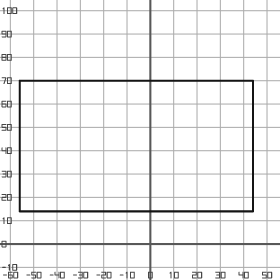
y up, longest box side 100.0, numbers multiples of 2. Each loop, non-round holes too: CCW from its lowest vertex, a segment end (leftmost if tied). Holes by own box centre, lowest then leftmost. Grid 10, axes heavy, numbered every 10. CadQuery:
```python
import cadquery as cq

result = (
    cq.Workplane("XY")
    .moveTo(-56.0, 14.0)
    .lineTo(44.0, 14.0)
    .lineTo(44.0, 70.0)
    .lineTo(-56.0, 70.0)
    .close()
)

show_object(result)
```